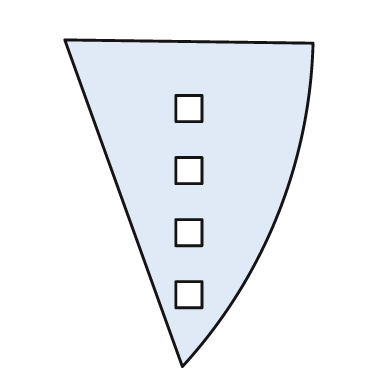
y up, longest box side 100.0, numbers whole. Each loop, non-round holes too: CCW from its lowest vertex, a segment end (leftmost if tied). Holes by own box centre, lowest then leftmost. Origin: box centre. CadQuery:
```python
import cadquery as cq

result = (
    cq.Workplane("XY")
    .moveTo(-2.0, -50.0)
    .threePointArc((27.0, -4.0), (38.0, 49.0))
    .lineTo(-38.0, 50.0)
    .close()
    .moveTo(-4.0, -32.0)
    .lineTo(4.0, -32.0)
    .lineTo(4.0, -24.0)
    .lineTo(-4.0, -24.0)
    .close()
    .moveTo(-4.0, -13.0)
    .lineTo(4.0, -13.0)
    .lineTo(4.0, -5.0)
    .lineTo(-4.0, -5.0)
    .close()
    .moveTo(-4.0, 6.0)
    .lineTo(4.0, 6.0)
    .lineTo(4.0, 14.0)
    .lineTo(-4.0, 14.0)
    .close()
    .moveTo(-4.0, 25.0)
    .lineTo(4.0, 25.0)
    .lineTo(4.0, 33.0)
    .lineTo(-4.0, 33.0)
    .close()
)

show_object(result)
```